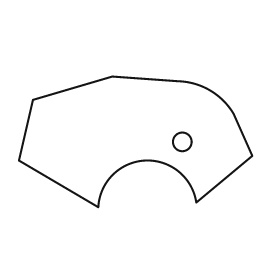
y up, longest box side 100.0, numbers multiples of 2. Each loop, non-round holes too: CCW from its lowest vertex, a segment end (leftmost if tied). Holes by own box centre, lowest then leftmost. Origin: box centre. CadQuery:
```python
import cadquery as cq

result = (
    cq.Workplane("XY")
    .moveTo(-16.0, -28.0)
    .threePointArc((4.0, -8.0), (26.0, -26.0))
    .lineTo(50.0, -6.0)
    .lineTo(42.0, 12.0)
    .threePointArc((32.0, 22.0), (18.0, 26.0))
    .lineTo(-10.0, 28.0)
    .lineTo(-44.0, 18.0)
    .lineTo(-50.0, -8.0)
    .close()
    .moveTo(20.0, 0.0)
    .circle(4.0)
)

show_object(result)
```